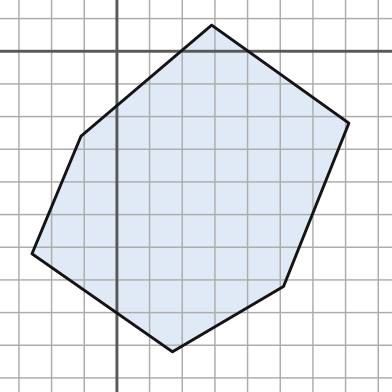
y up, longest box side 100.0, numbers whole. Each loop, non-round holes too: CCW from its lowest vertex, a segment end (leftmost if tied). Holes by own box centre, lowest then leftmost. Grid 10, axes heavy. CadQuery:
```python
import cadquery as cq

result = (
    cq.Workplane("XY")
    .moveTo(17.0, -92.0)
    .lineTo(51.0, -72.0)
    .lineTo(71.0, -22.0)
    .lineTo(29.0, 8.0)
    .lineTo(-11.0, -26.0)
    .lineTo(-26.0, -62.0)
    .close()
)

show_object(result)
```